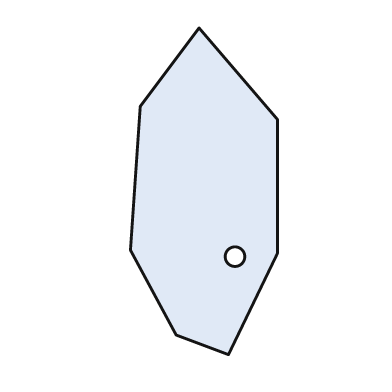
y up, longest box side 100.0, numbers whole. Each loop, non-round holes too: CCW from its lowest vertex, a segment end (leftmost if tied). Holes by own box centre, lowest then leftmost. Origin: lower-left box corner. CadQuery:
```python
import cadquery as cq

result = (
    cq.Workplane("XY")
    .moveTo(30.0, 0.0)
    .lineTo(45.0, 31.0)
    .lineTo(45.0, 72.0)
    .lineTo(21.0, 100.0)
    .lineTo(3.0, 76.0)
    .lineTo(0.0, 32.0)
    .lineTo(14.0, 6.0)
    .close()
    .moveTo(32.0, 30.0)
    .circle(3.0)
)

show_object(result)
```